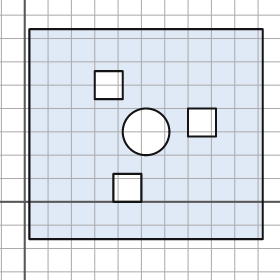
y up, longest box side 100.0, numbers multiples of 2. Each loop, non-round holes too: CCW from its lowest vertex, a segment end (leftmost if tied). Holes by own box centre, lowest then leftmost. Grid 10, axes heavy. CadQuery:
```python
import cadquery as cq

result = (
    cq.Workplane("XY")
    .moveTo(2.0, -16.0)
    .lineTo(102.0, -16.0)
    .lineTo(102.0, 74.0)
    .lineTo(2.0, 74.0)
    .close()
    .moveTo(38.0, 0.0)
    .lineTo(50.0, 0.0)
    .lineTo(50.0, 12.0)
    .lineTo(38.0, 12.0)
    .close()
    .moveTo(52.0, 30.0)
    .circle(10.0)
    .moveTo(70.0, 28.0)
    .lineTo(82.0, 28.0)
    .lineTo(82.0, 40.0)
    .lineTo(70.0, 40.0)
    .close()
    .moveTo(30.0, 44.0)
    .lineTo(42.0, 44.0)
    .lineTo(42.0, 56.0)
    .lineTo(30.0, 56.0)
    .close()
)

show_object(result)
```